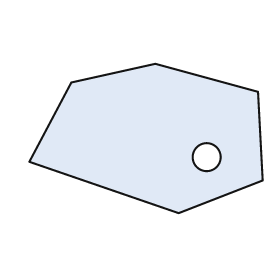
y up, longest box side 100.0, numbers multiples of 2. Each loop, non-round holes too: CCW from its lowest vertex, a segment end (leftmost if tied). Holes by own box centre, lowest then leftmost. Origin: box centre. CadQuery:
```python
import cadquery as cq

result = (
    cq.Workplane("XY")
    .moveTo(14.0, -32.0)
    .lineTo(50.0, -18.0)
    .lineTo(48.0, 20.0)
    .lineTo(4.0, 32.0)
    .lineTo(-32.0, 24.0)
    .lineTo(-50.0, -10.0)
    .close()
    .moveTo(26.0, -8.0)
    .circle(6.0)
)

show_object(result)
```